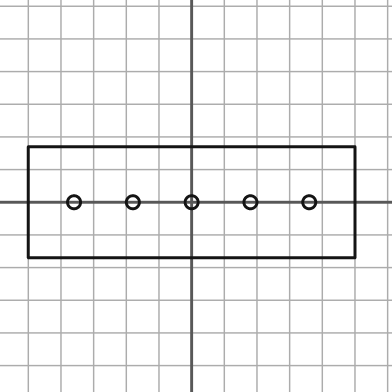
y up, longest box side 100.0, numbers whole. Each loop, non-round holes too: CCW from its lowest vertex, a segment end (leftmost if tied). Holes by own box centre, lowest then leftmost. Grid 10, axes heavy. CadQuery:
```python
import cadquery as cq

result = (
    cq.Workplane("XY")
    .moveTo(-50.0, -17.0)
    .lineTo(50.0, -17.0)
    .lineTo(50.0, 17.0)
    .lineTo(-50.0, 17.0)
    .close()
    .moveTo(-36.0, 0.0)
    .circle(2.0)
    .moveTo(-18.0, 0.0)
    .circle(2.0)
    .moveTo(0.0, 0.0)
    .circle(2.0)
    .moveTo(18.0, 0.0)
    .circle(2.0)
    .moveTo(36.0, 0.0)
    .circle(2.0)
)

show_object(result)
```